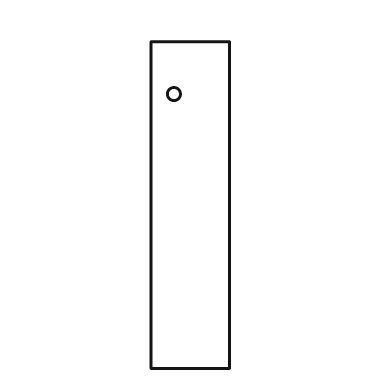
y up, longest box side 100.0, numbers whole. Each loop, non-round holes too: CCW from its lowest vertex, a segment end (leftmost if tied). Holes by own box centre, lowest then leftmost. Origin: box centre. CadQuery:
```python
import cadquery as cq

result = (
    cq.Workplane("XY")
    .moveTo(-12.0, -50.0)
    .lineTo(12.0, -50.0)
    .lineTo(12.0, 50.0)
    .lineTo(-12.0, 50.0)
    .close()
    .moveTo(-5.0, 34.0)
    .circle(2.0)
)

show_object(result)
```